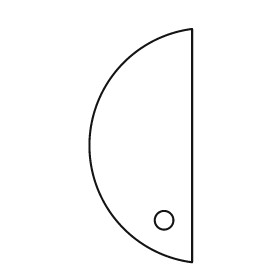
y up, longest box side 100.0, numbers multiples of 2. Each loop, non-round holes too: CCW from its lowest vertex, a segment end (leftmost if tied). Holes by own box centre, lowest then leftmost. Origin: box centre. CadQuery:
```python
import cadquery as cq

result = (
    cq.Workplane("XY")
    .moveTo(22.0, -50.0)
    .lineTo(22.0, 50.0)
    .threePointArc((-22.0, 0.0), (22.0, -50.0))
    .close()
    .moveTo(10.0, -32.0)
    .circle(4.0)
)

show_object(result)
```